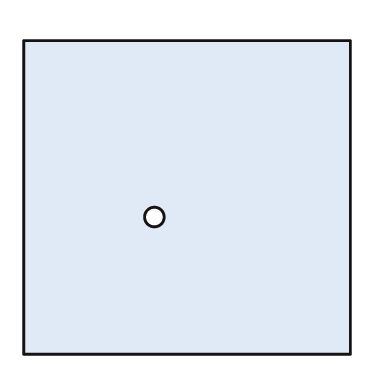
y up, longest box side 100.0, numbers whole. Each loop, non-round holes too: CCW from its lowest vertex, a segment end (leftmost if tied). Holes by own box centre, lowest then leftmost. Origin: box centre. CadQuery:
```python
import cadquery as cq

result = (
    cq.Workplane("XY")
    .moveTo(-50.0, -48.0)
    .lineTo(50.0, -48.0)
    .lineTo(50.0, 48.0)
    .lineTo(-50.0, 48.0)
    .close()
    .moveTo(-10.0, -6.0)
    .circle(3.0)
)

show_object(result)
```